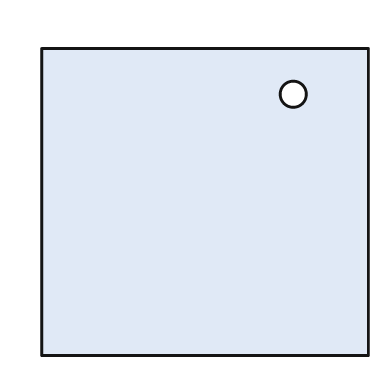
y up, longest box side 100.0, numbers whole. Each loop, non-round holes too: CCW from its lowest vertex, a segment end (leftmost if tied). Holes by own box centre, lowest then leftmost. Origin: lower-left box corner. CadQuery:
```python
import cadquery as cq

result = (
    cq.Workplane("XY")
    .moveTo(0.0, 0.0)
    .lineTo(100.0, 0.0)
    .lineTo(100.0, 94.0)
    .lineTo(0.0, 94.0)
    .close()
    .moveTo(77.0, 80.0)
    .circle(4.0)
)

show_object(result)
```